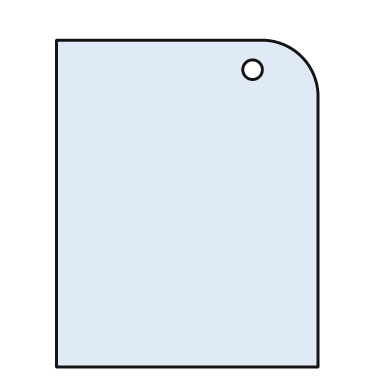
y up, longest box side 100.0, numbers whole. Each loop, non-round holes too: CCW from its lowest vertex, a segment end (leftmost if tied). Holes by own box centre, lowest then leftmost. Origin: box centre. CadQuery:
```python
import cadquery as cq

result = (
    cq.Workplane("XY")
    .moveTo(-40.0, -50.0)
    .lineTo(40.0, -50.0)
    .lineTo(40.0, 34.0)
    .threePointArc((35.0, 45.0), (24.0, 50.0))
    .lineTo(-40.0, 50.0)
    .close()
    .moveTo(20.0, 41.0)
    .circle(3.0)
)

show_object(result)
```